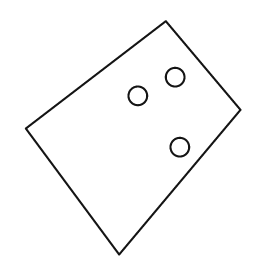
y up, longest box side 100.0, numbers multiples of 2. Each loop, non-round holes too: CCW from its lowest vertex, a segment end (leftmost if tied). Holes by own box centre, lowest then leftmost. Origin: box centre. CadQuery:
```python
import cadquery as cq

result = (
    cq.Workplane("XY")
    .moveTo(-6.0, -50.0)
    .lineTo(46.0, 12.0)
    .lineTo(14.0, 50.0)
    .lineTo(-46.0, 4.0)
    .close()
    .moveTo(20.0, -4.0)
    .circle(4.0)
    .moveTo(2.0, 18.0)
    .circle(4.0)
    .moveTo(18.0, 26.0)
    .circle(4.0)
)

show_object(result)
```